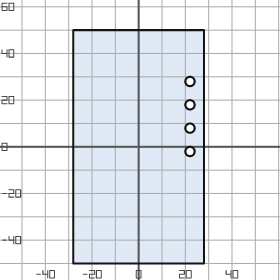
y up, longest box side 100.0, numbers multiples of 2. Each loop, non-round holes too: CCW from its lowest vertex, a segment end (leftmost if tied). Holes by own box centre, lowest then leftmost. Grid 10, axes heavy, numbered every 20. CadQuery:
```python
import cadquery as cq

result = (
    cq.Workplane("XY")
    .moveTo(-28.0, -50.0)
    .lineTo(28.0, -50.0)
    .lineTo(28.0, 50.0)
    .lineTo(-28.0, 50.0)
    .close()
    .moveTo(22.0, -2.0)
    .circle(2.0)
    .moveTo(22.0, 8.0)
    .circle(2.0)
    .moveTo(22.0, 18.0)
    .circle(2.0)
    .moveTo(22.0, 28.0)
    .circle(2.0)
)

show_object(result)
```